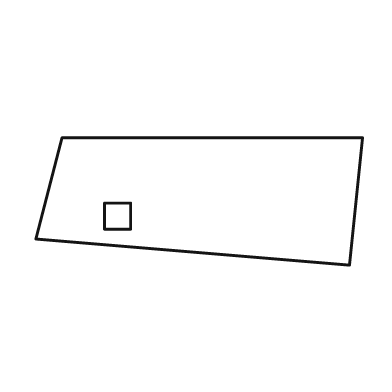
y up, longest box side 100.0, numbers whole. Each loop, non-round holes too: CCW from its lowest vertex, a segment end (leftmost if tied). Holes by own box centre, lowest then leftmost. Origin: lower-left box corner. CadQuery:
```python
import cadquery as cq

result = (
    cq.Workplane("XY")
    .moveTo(96.0, 0.0)
    .lineTo(100.0, 39.0)
    .lineTo(8.0, 39.0)
    .lineTo(0.0, 8.0)
    .close()
    .moveTo(21.0, 11.0)
    .lineTo(29.0, 11.0)
    .lineTo(29.0, 19.0)
    .lineTo(21.0, 19.0)
    .close()
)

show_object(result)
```